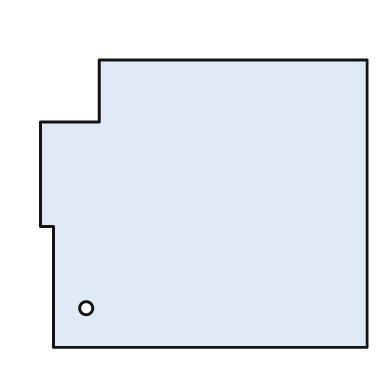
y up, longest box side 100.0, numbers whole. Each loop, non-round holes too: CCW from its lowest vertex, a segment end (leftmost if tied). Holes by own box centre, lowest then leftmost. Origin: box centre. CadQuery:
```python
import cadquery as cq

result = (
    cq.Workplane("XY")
    .moveTo(-46.0, -44.0)
    .lineTo(50.0, -44.0)
    .lineTo(50.0, 44.0)
    .lineTo(-32.0, 44.0)
    .lineTo(-32.0, 25.0)
    .lineTo(-50.0, 25.0)
    .lineTo(-50.0, -7.0)
    .lineTo(-46.0, -7.0)
    .close()
    .moveTo(-36.0, -32.0)
    .circle(2.0)
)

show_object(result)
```